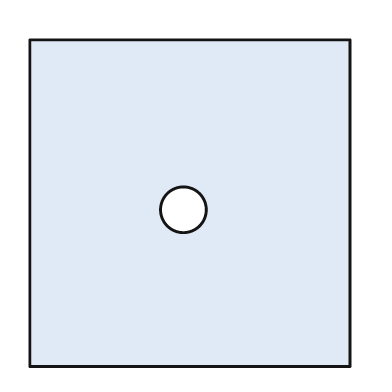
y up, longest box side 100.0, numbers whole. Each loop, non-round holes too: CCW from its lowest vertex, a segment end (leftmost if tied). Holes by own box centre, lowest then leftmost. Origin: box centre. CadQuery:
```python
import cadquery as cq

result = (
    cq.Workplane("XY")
    .moveTo(-49.0, -50.0)
    .lineTo(49.0, -50.0)
    .lineTo(49.0, 50.0)
    .lineTo(-49.0, 50.0)
    .close()
    .moveTo(-2.0, -2.0)
    .circle(7.0)
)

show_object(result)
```